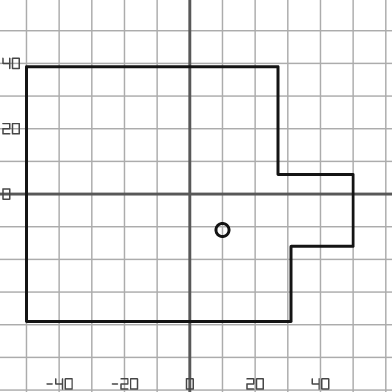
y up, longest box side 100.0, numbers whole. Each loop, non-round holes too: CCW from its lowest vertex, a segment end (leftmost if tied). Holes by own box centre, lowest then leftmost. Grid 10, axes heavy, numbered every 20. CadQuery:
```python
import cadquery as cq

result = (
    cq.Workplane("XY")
    .moveTo(-50.0, -39.0)
    .lineTo(31.0, -39.0)
    .lineTo(31.0, -16.0)
    .lineTo(50.0, -16.0)
    .lineTo(50.0, 6.0)
    .lineTo(27.0, 6.0)
    .lineTo(27.0, 39.0)
    .lineTo(-50.0, 39.0)
    .close()
    .moveTo(10.0, -11.0)
    .circle(2.0)
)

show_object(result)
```